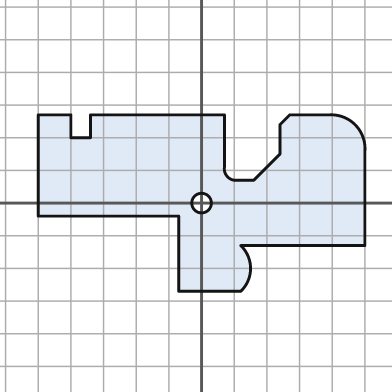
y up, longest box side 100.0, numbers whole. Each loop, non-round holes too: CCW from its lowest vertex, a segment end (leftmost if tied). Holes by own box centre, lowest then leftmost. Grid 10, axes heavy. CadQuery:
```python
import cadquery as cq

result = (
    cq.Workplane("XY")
    .moveTo(-7.0, -27.0)
    .lineTo(12.0, -27.0)
    .threePointArc((15.0, -20.0), (12.0, -13.0))
    .lineTo(50.0, -13.0)
    .lineTo(50.0, 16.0)
    .threePointArc((47.0, 24.0), (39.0, 27.0))
    .lineTo(27.0, 27.0)
    .lineTo(24.0, 24.0)
    .lineTo(24.0, 15.0)
    .lineTo(16.0, 7.0)
    .lineTo(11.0, 7.0)
    .threePointArc((8.0, 8.0), (7.0, 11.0))
    .lineTo(7.0, 27.0)
    .lineTo(-34.0, 27.0)
    .lineTo(-34.0, 20.0)
    .lineTo(-40.0, 20.0)
    .lineTo(-40.0, 27.0)
    .lineTo(-50.0, 27.0)
    .lineTo(-50.0, -4.0)
    .lineTo(-7.0, -4.0)
    .close()
    .moveTo(0.0, 0.0)
    .circle(3.0)
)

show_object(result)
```